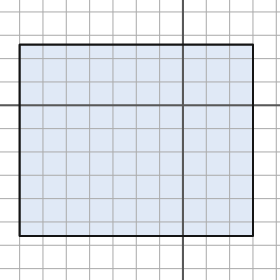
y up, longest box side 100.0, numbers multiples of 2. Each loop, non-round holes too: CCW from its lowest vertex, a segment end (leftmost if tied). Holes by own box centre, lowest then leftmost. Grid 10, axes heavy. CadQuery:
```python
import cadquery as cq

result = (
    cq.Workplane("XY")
    .moveTo(-70.0, -56.0)
    .lineTo(30.0, -56.0)
    .lineTo(30.0, 26.0)
    .lineTo(-70.0, 26.0)
    .close()
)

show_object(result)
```